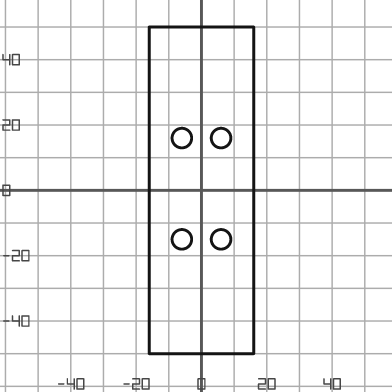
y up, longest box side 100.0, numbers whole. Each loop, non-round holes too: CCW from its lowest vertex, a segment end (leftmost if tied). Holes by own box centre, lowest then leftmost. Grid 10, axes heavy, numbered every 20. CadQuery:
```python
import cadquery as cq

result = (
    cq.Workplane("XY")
    .moveTo(-16.0, -50.0)
    .lineTo(16.0, -50.0)
    .lineTo(16.0, 50.0)
    .lineTo(-16.0, 50.0)
    .close()
    .moveTo(-6.0, -15.0)
    .circle(3.0)
    .moveTo(6.0, -15.0)
    .circle(3.0)
    .moveTo(-6.0, 16.0)
    .circle(3.0)
    .moveTo(6.0, 16.0)
    .circle(3.0)
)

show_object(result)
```